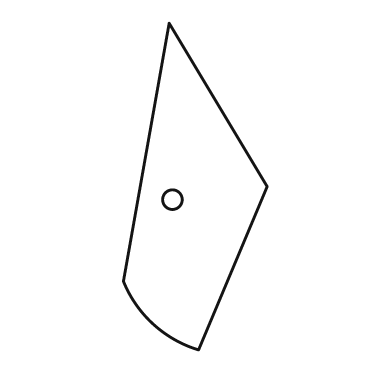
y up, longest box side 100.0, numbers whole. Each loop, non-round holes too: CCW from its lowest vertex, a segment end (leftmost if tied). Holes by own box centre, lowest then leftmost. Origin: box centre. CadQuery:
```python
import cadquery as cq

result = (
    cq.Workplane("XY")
    .moveTo(1.0, -50.0)
    .lineTo(22.0, 0.0)
    .lineTo(-8.0, 50.0)
    .lineTo(-22.0, -29.0)
    .threePointArc((-13.0, -42.0), (1.0, -50.0))
    .close()
    .moveTo(-7.0, -4.0)
    .circle(3.0)
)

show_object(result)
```